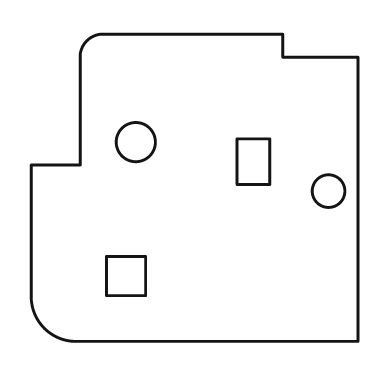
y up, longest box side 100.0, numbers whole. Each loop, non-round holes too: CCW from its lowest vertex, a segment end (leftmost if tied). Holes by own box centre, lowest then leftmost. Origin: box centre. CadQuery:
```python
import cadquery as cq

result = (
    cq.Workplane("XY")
    .moveTo(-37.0, -47.0)
    .lineTo(50.0, -47.0)
    .lineTo(50.0, 40.0)
    .lineTo(27.0, 40.0)
    .lineTo(27.0, 47.0)
    .lineTo(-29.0, 47.0)
    .threePointArc((-33.0, 45.0), (-35.0, 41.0))
    .lineTo(-35.0, 7.0)
    .lineTo(-50.0, 7.0)
    .lineTo(-50.0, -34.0)
    .threePointArc((-46.0, -43.0), (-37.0, -47.0))
    .close()
    .moveTo(-27.0, -33.0)
    .lineTo(-15.0, -33.0)
    .lineTo(-15.0, -21.0)
    .lineTo(-27.0, -21.0)
    .close()
    .moveTo(41.0, -1.0)
    .circle(5.0)
    .moveTo(13.0, 1.0)
    .lineTo(23.0, 1.0)
    .lineTo(23.0, 15.0)
    .lineTo(13.0, 15.0)
    .close()
    .moveTo(-18.0, 14.0)
    .circle(6.0)
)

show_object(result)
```